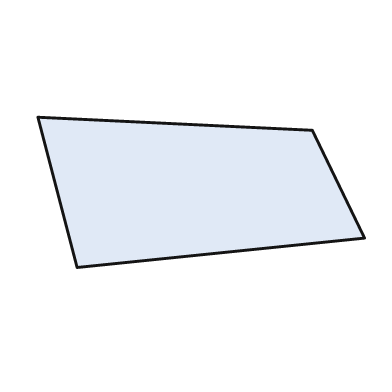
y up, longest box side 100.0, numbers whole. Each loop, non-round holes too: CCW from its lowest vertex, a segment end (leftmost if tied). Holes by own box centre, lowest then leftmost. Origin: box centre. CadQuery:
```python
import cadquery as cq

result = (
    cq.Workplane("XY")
    .moveTo(-38.0, -23.0)
    .lineTo(50.0, -14.0)
    .lineTo(34.0, 19.0)
    .lineTo(-50.0, 23.0)
    .close()
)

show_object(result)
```